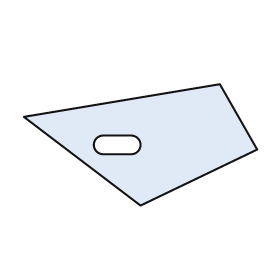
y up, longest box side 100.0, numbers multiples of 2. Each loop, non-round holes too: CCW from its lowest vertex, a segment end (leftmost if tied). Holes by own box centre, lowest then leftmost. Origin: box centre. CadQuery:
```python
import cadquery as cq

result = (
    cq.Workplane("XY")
    .moveTo(0.0, -26.0)
    .lineTo(50.0, -2.0)
    .lineTo(34.0, 26.0)
    .lineTo(-50.0, 12.0)
    .close()
    .moveTo(-16.0, -4.0)
    .lineTo(-4.0, -4.0)
    .threePointArc((0.0, 0.0), (-4.0, 4.0))
    .lineTo(-16.0, 4.0)
    .threePointArc((-20.0, 0.0), (-16.0, -4.0))
    .close()
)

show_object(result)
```